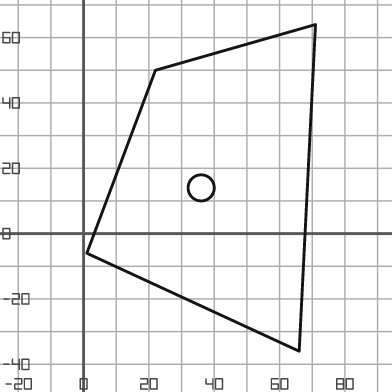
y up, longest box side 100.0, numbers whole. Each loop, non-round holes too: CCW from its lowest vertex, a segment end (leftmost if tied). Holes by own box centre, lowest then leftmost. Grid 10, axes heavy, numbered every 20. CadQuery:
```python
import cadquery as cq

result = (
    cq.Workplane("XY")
    .moveTo(66.0, -36.0)
    .lineTo(71.0, 64.0)
    .lineTo(22.0, 50.0)
    .lineTo(1.0, -6.0)
    .close()
    .moveTo(36.0, 14.0)
    .circle(4.0)
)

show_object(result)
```